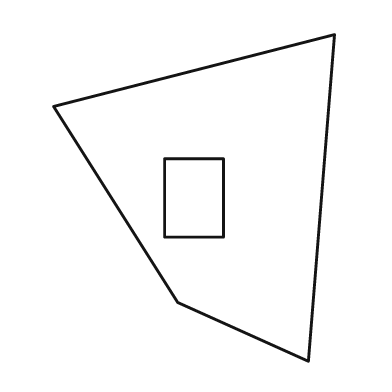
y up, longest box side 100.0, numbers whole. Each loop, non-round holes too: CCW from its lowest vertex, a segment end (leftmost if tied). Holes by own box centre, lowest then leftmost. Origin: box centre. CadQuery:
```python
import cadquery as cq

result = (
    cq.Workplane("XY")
    .moveTo(35.0, -50.0)
    .lineTo(43.0, 50.0)
    .lineTo(-43.0, 28.0)
    .lineTo(-5.0, -32.0)
    .close()
    .moveTo(-9.0, -12.0)
    .lineTo(9.0, -12.0)
    .lineTo(9.0, 12.0)
    .lineTo(-9.0, 12.0)
    .close()
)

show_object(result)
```